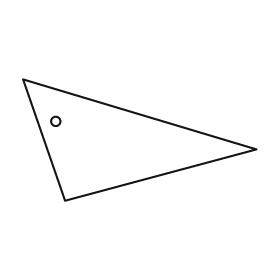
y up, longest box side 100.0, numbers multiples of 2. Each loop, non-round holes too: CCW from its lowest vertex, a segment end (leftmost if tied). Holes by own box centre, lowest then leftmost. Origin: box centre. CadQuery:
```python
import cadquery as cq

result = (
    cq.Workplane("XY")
    .moveTo(-32.0, -26.0)
    .lineTo(50.0, -4.0)
    .lineTo(-50.0, 26.0)
    .close()
    .moveTo(-36.0, 8.0)
    .circle(2.0)
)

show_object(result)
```